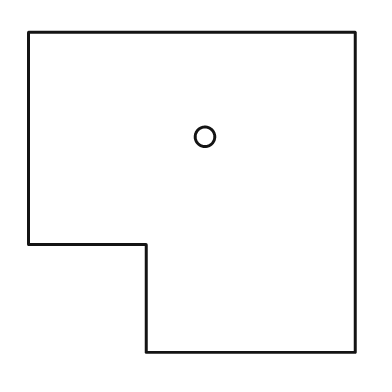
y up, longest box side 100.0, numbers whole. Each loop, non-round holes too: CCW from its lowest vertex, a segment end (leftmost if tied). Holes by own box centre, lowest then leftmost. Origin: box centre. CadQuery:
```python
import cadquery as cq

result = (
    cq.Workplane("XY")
    .moveTo(-14.0, -49.0)
    .lineTo(50.0, -49.0)
    .lineTo(50.0, 49.0)
    .lineTo(-50.0, 49.0)
    .lineTo(-50.0, -16.0)
    .lineTo(-14.0, -16.0)
    .close()
    .moveTo(4.0, 17.0)
    .circle(3.0)
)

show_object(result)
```